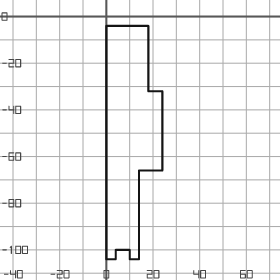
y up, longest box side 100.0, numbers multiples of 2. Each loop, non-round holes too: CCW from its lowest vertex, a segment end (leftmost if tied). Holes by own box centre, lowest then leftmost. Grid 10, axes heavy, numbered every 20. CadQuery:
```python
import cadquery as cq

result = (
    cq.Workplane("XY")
    .moveTo(0.0, -104.0)
    .lineTo(4.0, -104.0)
    .lineTo(4.0, -100.0)
    .lineTo(10.0, -100.0)
    .lineTo(10.0, -104.0)
    .lineTo(14.0, -104.0)
    .lineTo(14.0, -66.0)
    .lineTo(24.0, -66.0)
    .lineTo(24.0, -32.0)
    .lineTo(18.0, -32.0)
    .lineTo(18.0, -4.0)
    .lineTo(0.0, -4.0)
    .close()
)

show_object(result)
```